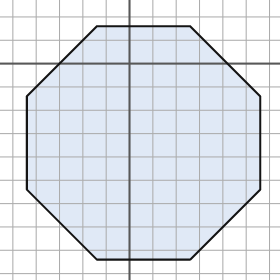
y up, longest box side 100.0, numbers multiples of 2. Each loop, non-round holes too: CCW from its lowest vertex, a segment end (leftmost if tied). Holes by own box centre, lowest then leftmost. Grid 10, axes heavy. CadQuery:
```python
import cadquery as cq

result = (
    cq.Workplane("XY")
    .moveTo(-14.0, -84.0)
    .lineTo(26.0, -84.0)
    .lineTo(56.0, -54.0)
    .lineTo(56.0, -14.0)
    .lineTo(26.0, 16.0)
    .lineTo(-14.0, 16.0)
    .lineTo(-44.0, -14.0)
    .lineTo(-44.0, -54.0)
    .close()
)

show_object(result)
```